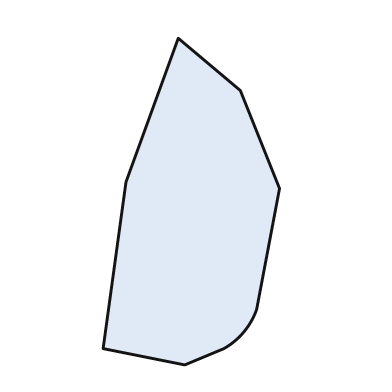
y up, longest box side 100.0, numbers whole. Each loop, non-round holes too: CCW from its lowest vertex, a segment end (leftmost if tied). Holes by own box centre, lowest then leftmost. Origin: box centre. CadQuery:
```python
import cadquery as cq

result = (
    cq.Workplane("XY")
    .moveTo(-2.0, -50.0)
    .lineTo(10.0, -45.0)
    .threePointArc((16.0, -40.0), (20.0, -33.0))
    .lineTo(27.0, 4.0)
    .lineTo(15.0, 34.0)
    .lineTo(-4.0, 50.0)
    .lineTo(-20.0, 6.0)
    .lineTo(-27.0, -45.0)
    .close()
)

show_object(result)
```